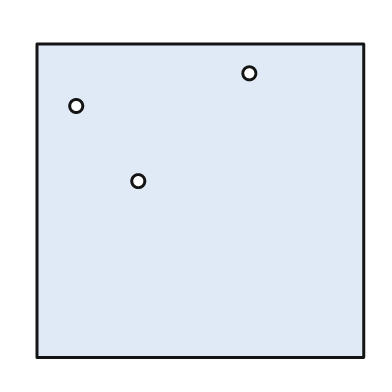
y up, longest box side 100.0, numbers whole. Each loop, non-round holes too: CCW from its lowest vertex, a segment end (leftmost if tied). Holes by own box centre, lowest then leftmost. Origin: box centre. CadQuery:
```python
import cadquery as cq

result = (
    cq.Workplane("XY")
    .moveTo(-50.0, -48.0)
    .lineTo(50.0, -48.0)
    .lineTo(50.0, 48.0)
    .lineTo(-50.0, 48.0)
    .close()
    .moveTo(-19.0, 6.0)
    .circle(2.0)
    .moveTo(-38.0, 29.0)
    .circle(2.0)
    .moveTo(15.0, 39.0)
    .circle(2.0)
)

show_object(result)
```